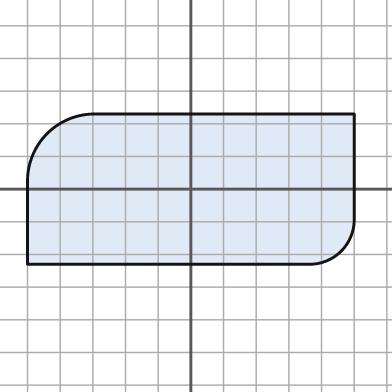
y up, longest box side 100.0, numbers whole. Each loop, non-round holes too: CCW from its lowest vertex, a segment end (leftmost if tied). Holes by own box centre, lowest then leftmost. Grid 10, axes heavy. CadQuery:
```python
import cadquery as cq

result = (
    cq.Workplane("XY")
    .moveTo(-50.0, -23.0)
    .lineTo(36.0, -23.0)
    .threePointArc((46.0, -19.0), (50.0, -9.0))
    .lineTo(50.0, 23.0)
    .lineTo(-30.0, 23.0)
    .threePointArc((-44.0, 17.0), (-50.0, 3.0))
    .close()
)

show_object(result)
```